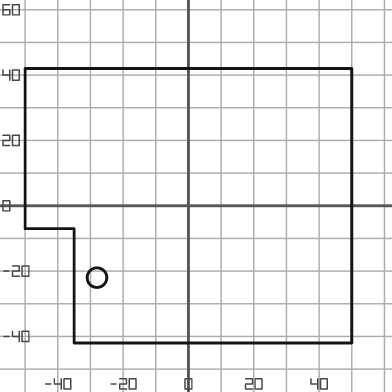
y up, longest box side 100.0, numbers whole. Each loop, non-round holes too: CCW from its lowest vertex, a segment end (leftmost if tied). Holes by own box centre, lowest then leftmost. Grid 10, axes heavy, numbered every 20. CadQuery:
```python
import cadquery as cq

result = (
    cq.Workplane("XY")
    .moveTo(-35.0, -42.0)
    .lineTo(50.0, -42.0)
    .lineTo(50.0, 42.0)
    .lineTo(-50.0, 42.0)
    .lineTo(-50.0, -7.0)
    .lineTo(-35.0, -7.0)
    .close()
    .moveTo(-28.0, -22.0)
    .circle(3.0)
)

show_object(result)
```